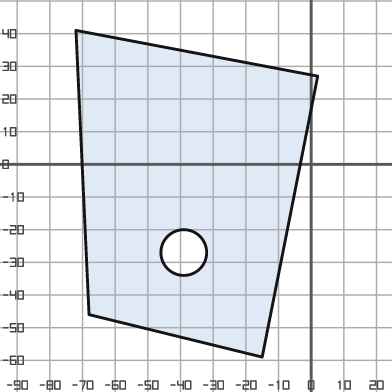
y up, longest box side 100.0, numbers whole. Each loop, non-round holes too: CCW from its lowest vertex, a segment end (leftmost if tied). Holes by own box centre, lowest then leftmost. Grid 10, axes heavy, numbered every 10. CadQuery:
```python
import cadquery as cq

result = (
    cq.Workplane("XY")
    .moveTo(-15.0, -59.0)
    .lineTo(2.0, 27.0)
    .lineTo(-72.0, 41.0)
    .lineTo(-68.0, -46.0)
    .close()
    .moveTo(-39.0, -27.0)
    .circle(7.0)
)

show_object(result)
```